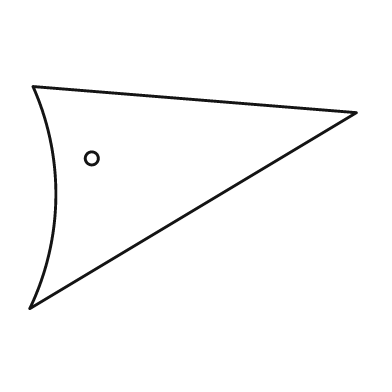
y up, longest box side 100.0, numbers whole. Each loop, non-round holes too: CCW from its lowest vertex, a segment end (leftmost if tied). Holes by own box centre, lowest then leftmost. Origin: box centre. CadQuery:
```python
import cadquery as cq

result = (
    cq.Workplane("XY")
    .moveTo(-50.0, -34.0)
    .lineTo(50.0, 26.0)
    .lineTo(-49.0, 34.0)
    .threePointArc((-42.0, 0.0), (-50.0, -34.0))
    .close()
    .moveTo(-31.0, 12.0)
    .circle(2.0)
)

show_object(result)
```